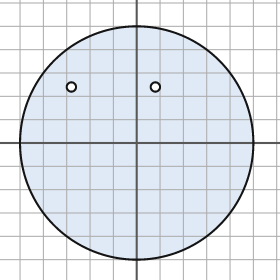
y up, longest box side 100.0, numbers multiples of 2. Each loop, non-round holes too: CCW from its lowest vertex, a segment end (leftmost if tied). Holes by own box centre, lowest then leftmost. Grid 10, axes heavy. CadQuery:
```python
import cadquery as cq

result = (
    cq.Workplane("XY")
    .moveTo(0.0, 0.0)
    .circle(50.0)
    .moveTo(-28.0, 24.0)
    .circle(2.0)
    .moveTo(8.0, 24.0)
    .circle(2.0)
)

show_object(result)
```